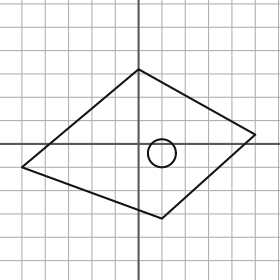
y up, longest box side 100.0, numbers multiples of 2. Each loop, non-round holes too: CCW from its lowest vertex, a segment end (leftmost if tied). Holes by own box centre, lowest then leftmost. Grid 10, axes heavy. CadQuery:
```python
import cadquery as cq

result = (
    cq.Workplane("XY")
    .moveTo(10.0, -32.0)
    .lineTo(50.0, 4.0)
    .lineTo(0.0, 32.0)
    .lineTo(-50.0, -10.0)
    .close()
    .moveTo(10.0, -4.0)
    .circle(6.0)
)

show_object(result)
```